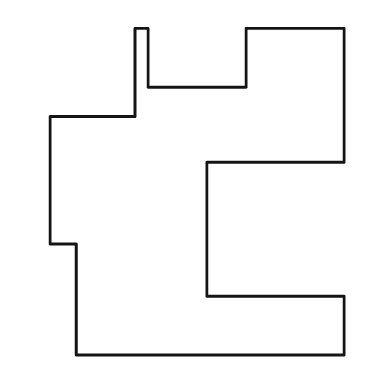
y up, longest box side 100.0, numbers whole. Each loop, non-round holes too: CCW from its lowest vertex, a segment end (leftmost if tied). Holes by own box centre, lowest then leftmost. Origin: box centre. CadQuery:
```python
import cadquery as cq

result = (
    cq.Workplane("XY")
    .moveTo(-37.0, -50.0)
    .lineTo(45.0, -50.0)
    .lineTo(45.0, -32.0)
    .lineTo(3.0, -32.0)
    .lineTo(3.0, 9.0)
    .lineTo(45.0, 9.0)
    .lineTo(45.0, 50.0)
    .lineTo(15.0, 50.0)
    .lineTo(15.0, 32.0)
    .lineTo(-15.0, 32.0)
    .lineTo(-15.0, 50.0)
    .lineTo(-19.0, 50.0)
    .lineTo(-19.0, 23.0)
    .lineTo(-45.0, 23.0)
    .lineTo(-45.0, -16.0)
    .lineTo(-37.0, -16.0)
    .close()
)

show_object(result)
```